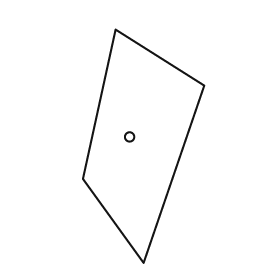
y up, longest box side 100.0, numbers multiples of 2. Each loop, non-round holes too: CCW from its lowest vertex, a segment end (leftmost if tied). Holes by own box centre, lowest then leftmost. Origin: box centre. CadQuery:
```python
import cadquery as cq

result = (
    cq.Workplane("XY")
    .moveTo(0.0, -50.0)
    .lineTo(26.0, 26.0)
    .lineTo(-12.0, 50.0)
    .lineTo(-26.0, -14.0)
    .close()
    .moveTo(-6.0, 4.0)
    .circle(2.0)
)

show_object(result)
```